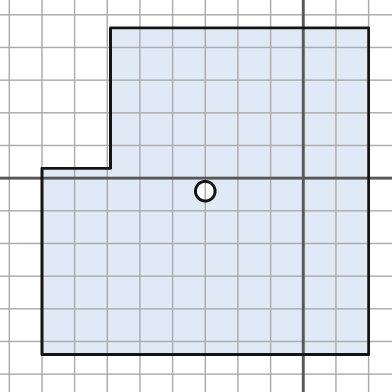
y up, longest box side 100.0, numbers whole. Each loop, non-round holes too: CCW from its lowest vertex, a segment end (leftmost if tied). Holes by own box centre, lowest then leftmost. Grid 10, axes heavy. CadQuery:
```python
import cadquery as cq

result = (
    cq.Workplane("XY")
    .moveTo(-80.0, -54.0)
    .lineTo(20.0, -54.0)
    .lineTo(20.0, 46.0)
    .lineTo(-59.0, 46.0)
    .lineTo(-59.0, 3.0)
    .lineTo(-80.0, 3.0)
    .close()
    .moveTo(-30.0, -4.0)
    .circle(3.0)
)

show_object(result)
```